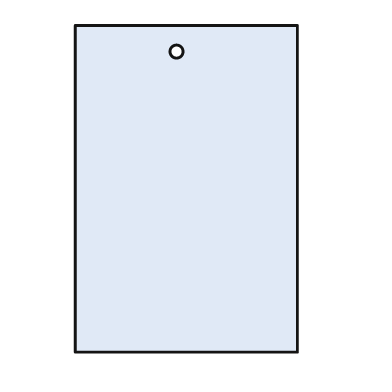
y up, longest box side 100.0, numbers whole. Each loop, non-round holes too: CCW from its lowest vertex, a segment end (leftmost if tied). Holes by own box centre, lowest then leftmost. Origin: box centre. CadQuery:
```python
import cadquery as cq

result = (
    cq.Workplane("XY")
    .moveTo(-34.0, -50.0)
    .lineTo(34.0, -50.0)
    .lineTo(34.0, 50.0)
    .lineTo(-34.0, 50.0)
    .close()
    .moveTo(-3.0, 42.0)
    .circle(2.0)
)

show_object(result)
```